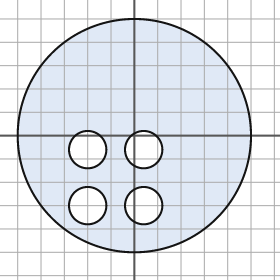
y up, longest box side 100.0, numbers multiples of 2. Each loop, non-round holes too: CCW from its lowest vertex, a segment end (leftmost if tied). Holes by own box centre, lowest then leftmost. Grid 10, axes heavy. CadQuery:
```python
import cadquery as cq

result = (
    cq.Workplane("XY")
    .moveTo(0.0, 0.0)
    .circle(50.0)
    .moveTo(-20.0, -30.0)
    .circle(8.0)
    .moveTo(4.0, -30.0)
    .circle(8.0)
    .moveTo(-20.0, -6.0)
    .circle(8.0)
    .moveTo(4.0, -6.0)
    .circle(8.0)
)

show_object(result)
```